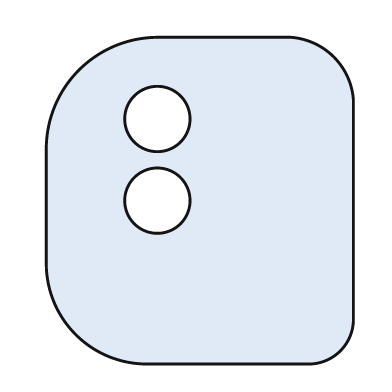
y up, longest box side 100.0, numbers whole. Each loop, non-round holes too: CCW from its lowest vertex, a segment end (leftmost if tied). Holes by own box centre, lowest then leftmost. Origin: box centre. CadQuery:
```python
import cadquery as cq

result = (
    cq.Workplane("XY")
    .moveTo(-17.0, -50.0)
    .lineTo(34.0, -50.0)
    .threePointArc((43.0, -46.0), (47.0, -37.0))
    .lineTo(47.0, 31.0)
    .threePointArc((41.0, 44.0), (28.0, 50.0))
    .lineTo(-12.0, 50.0)
    .threePointArc((-37.0, 40.0), (-47.0, 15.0))
    .lineTo(-47.0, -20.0)
    .threePointArc((-38.0, -41.0), (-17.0, -50.0))
    .close()
    .moveTo(-13.0, 0.0)
    .circle(10.0)
    .moveTo(-13.0, 25.0)
    .circle(10.0)
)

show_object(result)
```